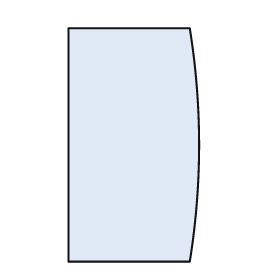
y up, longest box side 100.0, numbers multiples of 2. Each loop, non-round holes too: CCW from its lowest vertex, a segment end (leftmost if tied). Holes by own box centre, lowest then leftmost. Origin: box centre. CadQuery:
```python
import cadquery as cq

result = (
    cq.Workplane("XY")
    .moveTo(-28.0, -50.0)
    .lineTo(24.0, -50.0)
    .threePointArc((28.0, 0.0), (24.0, 50.0))
    .lineTo(-28.0, 50.0)
    .close()
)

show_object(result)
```